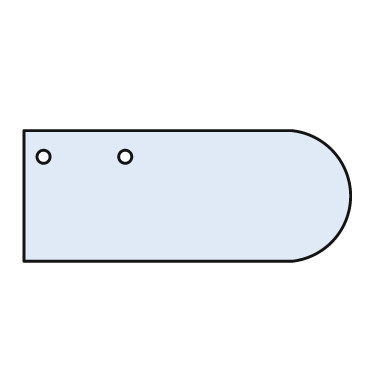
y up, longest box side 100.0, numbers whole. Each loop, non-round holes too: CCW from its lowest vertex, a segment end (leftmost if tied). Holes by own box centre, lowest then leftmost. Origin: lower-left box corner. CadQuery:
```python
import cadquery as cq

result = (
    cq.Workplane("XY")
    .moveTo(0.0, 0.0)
    .lineTo(82.0, 0.0)
    .threePointArc((100.0, 20.0), (82.0, 40.0))
    .lineTo(0.0, 40.0)
    .close()
    .moveTo(6.0, 32.0)
    .circle(2.0)
    .moveTo(31.0, 32.0)
    .circle(2.0)
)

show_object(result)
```